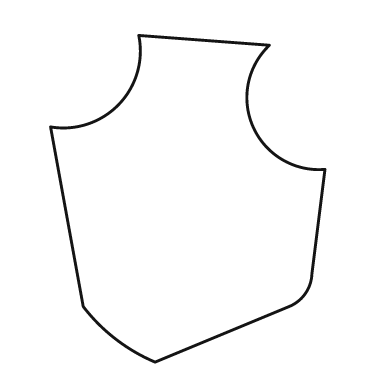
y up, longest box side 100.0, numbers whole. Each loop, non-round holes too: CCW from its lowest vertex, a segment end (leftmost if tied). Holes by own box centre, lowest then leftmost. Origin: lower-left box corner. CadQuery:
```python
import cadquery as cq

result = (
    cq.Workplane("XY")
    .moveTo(32.0, 0.0)
    .lineTo(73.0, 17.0)
    .threePointArc((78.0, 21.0), (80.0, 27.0))
    .lineTo(84.0, 59.0)
    .threePointArc((62.0, 72.0), (67.0, 97.0))
    .lineTo(27.0, 100.0)
    .threePointArc((21.0, 79.0), (0.0, 72.0))
    .lineTo(10.0, 17.0)
    .threePointArc((20.0, 7.0), (32.0, 0.0))
    .close()
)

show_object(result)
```